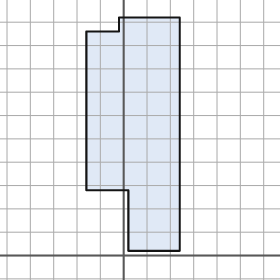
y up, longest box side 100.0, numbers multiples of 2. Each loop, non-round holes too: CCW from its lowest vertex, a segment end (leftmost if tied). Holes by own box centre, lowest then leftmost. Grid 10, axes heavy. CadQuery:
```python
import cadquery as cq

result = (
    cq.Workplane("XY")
    .moveTo(2.0, 2.0)
    .lineTo(24.0, 2.0)
    .lineTo(24.0, 102.0)
    .lineTo(-2.0, 102.0)
    .lineTo(-2.0, 96.0)
    .lineTo(-16.0, 96.0)
    .lineTo(-16.0, 28.0)
    .lineTo(2.0, 28.0)
    .close()
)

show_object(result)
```